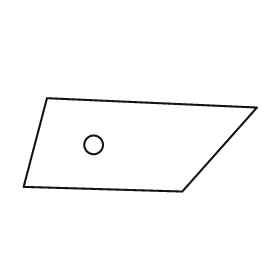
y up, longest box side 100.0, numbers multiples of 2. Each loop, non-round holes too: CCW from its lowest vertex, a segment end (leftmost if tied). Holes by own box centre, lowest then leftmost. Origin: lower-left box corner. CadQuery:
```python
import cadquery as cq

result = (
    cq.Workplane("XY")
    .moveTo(68.0, 0.0)
    .lineTo(100.0, 36.0)
    .lineTo(10.0, 40.0)
    .lineTo(0.0, 2.0)
    .close()
    .moveTo(30.0, 20.0)
    .circle(4.0)
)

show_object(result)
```